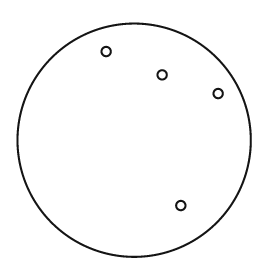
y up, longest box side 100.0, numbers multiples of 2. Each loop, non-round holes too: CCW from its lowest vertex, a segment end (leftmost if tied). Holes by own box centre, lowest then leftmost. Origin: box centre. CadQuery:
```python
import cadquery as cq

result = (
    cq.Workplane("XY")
    .moveTo(0.0, 0.0)
    .circle(50.0)
    .moveTo(20.0, -28.0)
    .circle(2.0)
    .moveTo(36.0, 20.0)
    .circle(2.0)
    .moveTo(12.0, 28.0)
    .circle(2.0)
    .moveTo(-12.0, 38.0)
    .circle(2.0)
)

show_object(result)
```